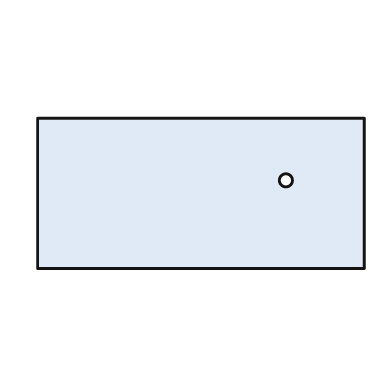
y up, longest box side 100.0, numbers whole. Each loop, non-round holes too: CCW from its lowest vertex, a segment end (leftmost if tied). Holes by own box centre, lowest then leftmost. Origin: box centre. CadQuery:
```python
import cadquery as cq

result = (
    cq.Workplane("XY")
    .moveTo(-50.0, -23.0)
    .lineTo(50.0, -23.0)
    .lineTo(50.0, 23.0)
    .lineTo(-50.0, 23.0)
    .close()
    .moveTo(26.0, 4.0)
    .circle(2.0)
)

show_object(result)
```